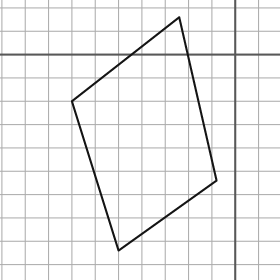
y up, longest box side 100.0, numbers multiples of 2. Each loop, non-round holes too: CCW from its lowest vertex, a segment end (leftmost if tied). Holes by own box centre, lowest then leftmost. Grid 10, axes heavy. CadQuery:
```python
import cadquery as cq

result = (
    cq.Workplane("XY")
    .moveTo(-50.0, -84.0)
    .lineTo(-8.0, -54.0)
    .lineTo(-24.0, 16.0)
    .lineTo(-70.0, -20.0)
    .close()
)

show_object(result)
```